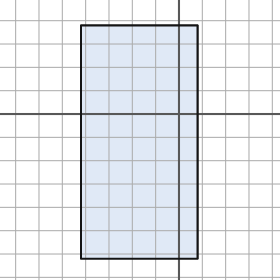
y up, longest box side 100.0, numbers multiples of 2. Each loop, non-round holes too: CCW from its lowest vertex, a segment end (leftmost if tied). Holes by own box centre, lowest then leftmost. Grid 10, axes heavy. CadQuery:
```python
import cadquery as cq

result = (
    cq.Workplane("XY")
    .moveTo(-42.0, -62.0)
    .lineTo(8.0, -62.0)
    .lineTo(8.0, 38.0)
    .lineTo(-42.0, 38.0)
    .close()
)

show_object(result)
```